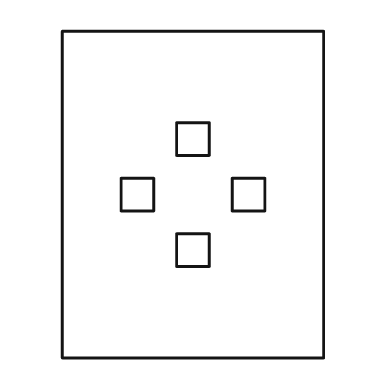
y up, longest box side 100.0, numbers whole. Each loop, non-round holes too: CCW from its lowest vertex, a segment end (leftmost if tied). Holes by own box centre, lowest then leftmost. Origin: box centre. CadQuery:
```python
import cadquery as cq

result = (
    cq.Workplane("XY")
    .moveTo(-40.0, -50.0)
    .lineTo(40.0, -50.0)
    .lineTo(40.0, 50.0)
    .lineTo(-40.0, 50.0)
    .close()
    .moveTo(-5.0, -22.0)
    .lineTo(5.0, -22.0)
    .lineTo(5.0, -12.0)
    .lineTo(-5.0, -12.0)
    .close()
    .moveTo(-22.0, -5.0)
    .lineTo(-12.0, -5.0)
    .lineTo(-12.0, 5.0)
    .lineTo(-22.0, 5.0)
    .close()
    .moveTo(12.0, -5.0)
    .lineTo(22.0, -5.0)
    .lineTo(22.0, 5.0)
    .lineTo(12.0, 5.0)
    .close()
    .moveTo(-5.0, 12.0)
    .lineTo(5.0, 12.0)
    .lineTo(5.0, 22.0)
    .lineTo(-5.0, 22.0)
    .close()
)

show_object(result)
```